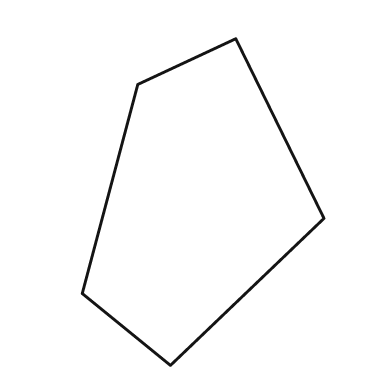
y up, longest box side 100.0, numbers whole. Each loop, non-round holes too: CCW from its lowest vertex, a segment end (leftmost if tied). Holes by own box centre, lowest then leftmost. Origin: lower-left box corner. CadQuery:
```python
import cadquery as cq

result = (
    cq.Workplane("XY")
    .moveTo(27.0, 0.0)
    .lineTo(74.0, 45.0)
    .lineTo(47.0, 100.0)
    .lineTo(17.0, 86.0)
    .lineTo(0.0, 22.0)
    .close()
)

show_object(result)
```